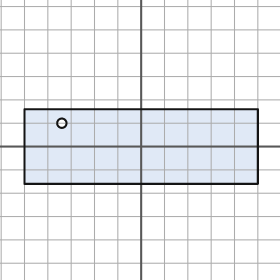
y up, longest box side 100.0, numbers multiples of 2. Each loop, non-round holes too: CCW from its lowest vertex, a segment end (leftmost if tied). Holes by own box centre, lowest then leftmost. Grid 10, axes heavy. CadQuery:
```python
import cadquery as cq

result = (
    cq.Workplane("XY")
    .moveTo(-50.0, -16.0)
    .lineTo(50.0, -16.0)
    .lineTo(50.0, 16.0)
    .lineTo(-50.0, 16.0)
    .close()
    .moveTo(-34.0, 10.0)
    .circle(2.0)
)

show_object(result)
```